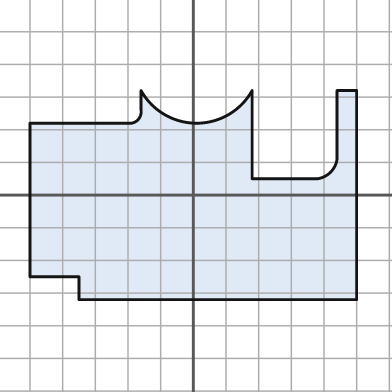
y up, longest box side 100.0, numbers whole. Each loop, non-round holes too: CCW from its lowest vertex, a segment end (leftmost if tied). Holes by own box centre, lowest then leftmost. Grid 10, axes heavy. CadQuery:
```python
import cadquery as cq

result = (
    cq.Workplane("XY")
    .moveTo(-35.0, -32.0)
    .lineTo(50.0, -32.0)
    .lineTo(50.0, 32.0)
    .lineTo(44.0, 32.0)
    .lineTo(44.0, 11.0)
    .threePointArc((42.0, 7.0), (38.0, 5.0))
    .lineTo(18.0, 5.0)
    .lineTo(18.0, 32.0)
    .threePointArc((1.0, 22.0), (-16.0, 32.0))
    .lineTo(-16.0, 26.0)
    .threePointArc((-17.0, 23.0), (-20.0, 22.0))
    .lineTo(-50.0, 22.0)
    .lineTo(-50.0, -25.0)
    .lineTo(-35.0, -25.0)
    .close()
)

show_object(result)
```